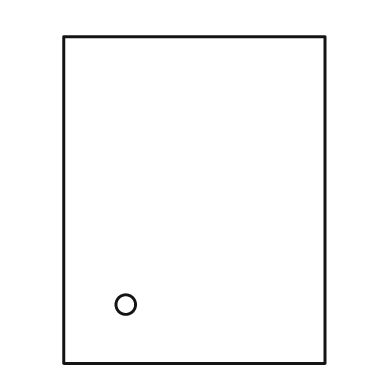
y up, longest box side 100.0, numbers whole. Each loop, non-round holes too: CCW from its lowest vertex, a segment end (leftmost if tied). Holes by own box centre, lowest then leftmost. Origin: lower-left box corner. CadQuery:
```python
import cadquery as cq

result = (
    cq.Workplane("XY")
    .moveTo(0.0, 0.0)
    .lineTo(80.0, 0.0)
    .lineTo(80.0, 100.0)
    .lineTo(0.0, 100.0)
    .close()
    .moveTo(19.0, 18.0)
    .circle(3.0)
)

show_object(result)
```